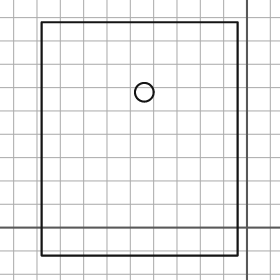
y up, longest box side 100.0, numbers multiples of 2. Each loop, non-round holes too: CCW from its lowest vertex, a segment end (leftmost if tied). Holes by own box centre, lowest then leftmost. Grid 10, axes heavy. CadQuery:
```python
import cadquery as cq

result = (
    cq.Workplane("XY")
    .moveTo(-88.0, -12.0)
    .lineTo(-4.0, -12.0)
    .lineTo(-4.0, 88.0)
    .lineTo(-88.0, 88.0)
    .close()
    .moveTo(-44.0, 58.0)
    .circle(4.0)
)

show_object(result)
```